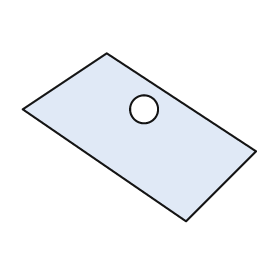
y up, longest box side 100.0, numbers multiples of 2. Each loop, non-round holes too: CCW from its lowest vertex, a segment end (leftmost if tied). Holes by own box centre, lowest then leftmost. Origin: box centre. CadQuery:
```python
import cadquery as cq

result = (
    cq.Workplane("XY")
    .moveTo(20.0, -36.0)
    .lineTo(50.0, -6.0)
    .lineTo(-14.0, 36.0)
    .lineTo(-50.0, 12.0)
    .close()
    .moveTo(2.0, 12.0)
    .circle(6.0)
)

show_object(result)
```